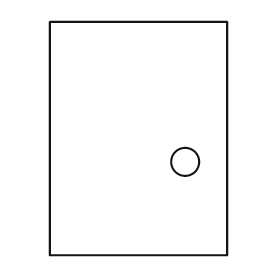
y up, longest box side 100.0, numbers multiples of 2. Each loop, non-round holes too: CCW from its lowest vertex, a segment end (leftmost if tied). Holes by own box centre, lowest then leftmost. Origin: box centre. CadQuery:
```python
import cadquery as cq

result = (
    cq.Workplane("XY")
    .moveTo(-38.0, -50.0)
    .lineTo(38.0, -50.0)
    .lineTo(38.0, 50.0)
    .lineTo(-38.0, 50.0)
    .close()
    .moveTo(20.0, -10.0)
    .circle(6.0)
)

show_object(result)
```